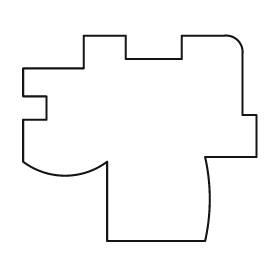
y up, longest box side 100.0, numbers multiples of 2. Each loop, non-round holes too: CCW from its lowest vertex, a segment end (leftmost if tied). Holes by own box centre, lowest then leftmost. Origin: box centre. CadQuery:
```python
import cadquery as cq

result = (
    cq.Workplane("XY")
    .moveTo(-14.0, -44.0)
    .lineTo(28.0, -44.0)
    .threePointArc((30.0, -26.0), (28.0, -8.0))
    .lineTo(50.0, -8.0)
    .lineTo(50.0, 10.0)
    .lineTo(44.0, 10.0)
    .lineTo(44.0, 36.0)
    .threePointArc((42.0, 42.0), (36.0, 44.0))
    .lineTo(18.0, 44.0)
    .lineTo(18.0, 34.0)
    .lineTo(-6.0, 34.0)
    .lineTo(-6.0, 44.0)
    .lineTo(-24.0, 44.0)
    .lineTo(-24.0, 30.0)
    .lineTo(-50.0, 30.0)
    .lineTo(-50.0, 18.0)
    .lineTo(-40.0, 18.0)
    .lineTo(-40.0, 8.0)
    .lineTo(-50.0, 8.0)
    .lineTo(-50.0, -10.0)
    .threePointArc((-32.0, -16.0), (-14.0, -10.0))
    .close()
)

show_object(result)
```